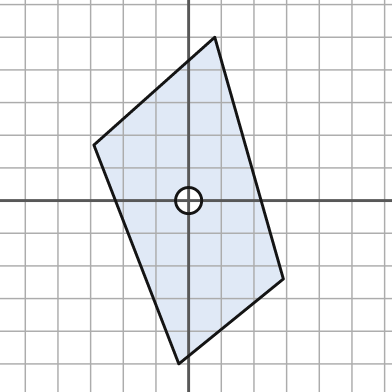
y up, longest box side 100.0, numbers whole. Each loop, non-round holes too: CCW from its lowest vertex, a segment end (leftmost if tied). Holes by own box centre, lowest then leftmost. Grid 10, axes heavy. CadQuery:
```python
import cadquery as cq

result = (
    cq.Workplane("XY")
    .moveTo(-3.0, -50.0)
    .lineTo(29.0, -24.0)
    .lineTo(8.0, 50.0)
    .lineTo(-29.0, 17.0)
    .close()
    .moveTo(0.0, 0.0)
    .circle(4.0)
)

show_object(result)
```